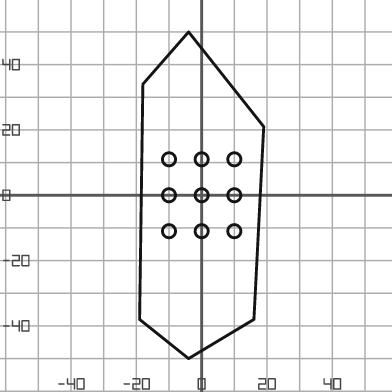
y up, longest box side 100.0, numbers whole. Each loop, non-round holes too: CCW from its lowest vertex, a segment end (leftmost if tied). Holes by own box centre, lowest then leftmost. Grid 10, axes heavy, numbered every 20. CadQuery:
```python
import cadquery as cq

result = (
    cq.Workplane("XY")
    .moveTo(-4.0, -50.0)
    .lineTo(16.0, -38.0)
    .lineTo(19.0, 21.0)
    .lineTo(-4.0, 50.0)
    .lineTo(-18.0, 34.0)
    .lineTo(-19.0, -38.0)
    .close()
    .moveTo(-10.0, -11.0)
    .circle(2.0)
    .moveTo(0.0, -11.0)
    .circle(2.0)
    .moveTo(10.0, -11.0)
    .circle(2.0)
    .moveTo(-10.0, 0.0)
    .circle(2.0)
    .moveTo(0.0, 0.0)
    .circle(2.0)
    .moveTo(10.0, 0.0)
    .circle(2.0)
    .moveTo(-10.0, 11.0)
    .circle(2.0)
    .moveTo(0.0, 11.0)
    .circle(2.0)
    .moveTo(10.0, 11.0)
    .circle(2.0)
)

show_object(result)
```